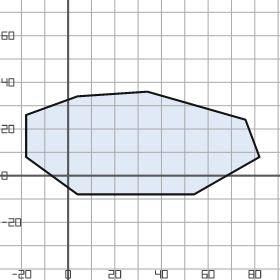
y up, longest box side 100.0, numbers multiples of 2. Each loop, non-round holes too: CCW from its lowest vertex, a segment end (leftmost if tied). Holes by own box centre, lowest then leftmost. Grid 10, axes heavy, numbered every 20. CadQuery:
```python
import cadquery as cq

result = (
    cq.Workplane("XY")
    .moveTo(4.0, -8.0)
    .lineTo(54.0, -8.0)
    .lineTo(82.0, 8.0)
    .lineTo(76.0, 24.0)
    .lineTo(34.0, 36.0)
    .lineTo(4.0, 34.0)
    .lineTo(-18.0, 26.0)
    .lineTo(-18.0, 8.0)
    .close()
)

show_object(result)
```